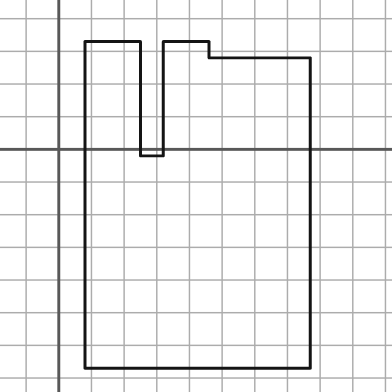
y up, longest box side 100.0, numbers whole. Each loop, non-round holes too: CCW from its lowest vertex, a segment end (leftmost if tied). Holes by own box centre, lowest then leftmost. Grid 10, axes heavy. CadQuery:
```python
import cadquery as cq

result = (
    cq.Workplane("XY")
    .moveTo(8.0, -67.0)
    .lineTo(77.0, -67.0)
    .lineTo(77.0, 28.0)
    .lineTo(46.0, 28.0)
    .lineTo(46.0, 33.0)
    .lineTo(32.0, 33.0)
    .lineTo(32.0, -2.0)
    .lineTo(25.0, -2.0)
    .lineTo(25.0, 33.0)
    .lineTo(8.0, 33.0)
    .close()
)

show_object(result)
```